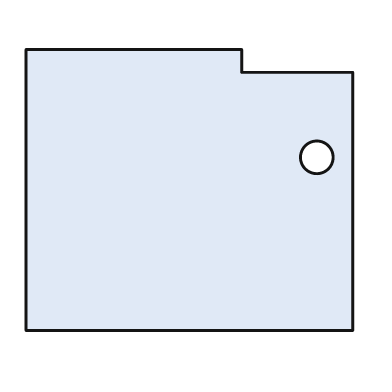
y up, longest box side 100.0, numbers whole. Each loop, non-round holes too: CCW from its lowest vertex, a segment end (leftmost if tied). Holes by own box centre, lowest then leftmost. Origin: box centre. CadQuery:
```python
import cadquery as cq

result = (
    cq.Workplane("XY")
    .moveTo(-50.0, -43.0)
    .lineTo(50.0, -43.0)
    .lineTo(50.0, 36.0)
    .lineTo(16.0, 36.0)
    .lineTo(16.0, 43.0)
    .lineTo(-50.0, 43.0)
    .close()
    .moveTo(39.0, 10.0)
    .circle(5.0)
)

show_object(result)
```